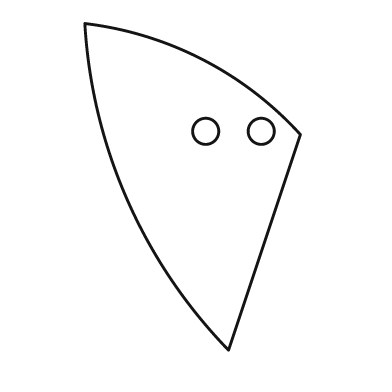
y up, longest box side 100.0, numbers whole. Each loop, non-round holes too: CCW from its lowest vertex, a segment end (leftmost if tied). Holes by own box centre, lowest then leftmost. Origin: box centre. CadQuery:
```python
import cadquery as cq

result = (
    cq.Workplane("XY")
    .moveTo(11.0, -50.0)
    .lineTo(33.0, 16.0)
    .threePointArc((3.0, 39.0), (-33.0, 50.0))
    .threePointArc((-20.0, -4.0), (11.0, -50.0))
    .close()
    .moveTo(4.0, 17.0)
    .circle(4.0)
    .moveTo(21.0, 17.0)
    .circle(4.0)
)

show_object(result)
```